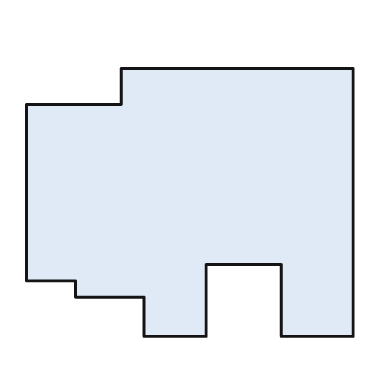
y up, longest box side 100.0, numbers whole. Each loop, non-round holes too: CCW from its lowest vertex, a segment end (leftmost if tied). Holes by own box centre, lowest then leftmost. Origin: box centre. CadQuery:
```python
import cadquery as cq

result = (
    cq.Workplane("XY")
    .moveTo(-14.0, -41.0)
    .lineTo(5.0, -41.0)
    .lineTo(5.0, -19.0)
    .lineTo(28.0, -19.0)
    .lineTo(28.0, -41.0)
    .lineTo(50.0, -41.0)
    .lineTo(50.0, 41.0)
    .lineTo(-21.0, 41.0)
    .lineTo(-21.0, 30.0)
    .lineTo(-50.0, 30.0)
    .lineTo(-50.0, -24.0)
    .lineTo(-35.0, -24.0)
    .lineTo(-35.0, -29.0)
    .lineTo(-14.0, -29.0)
    .close()
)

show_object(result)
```